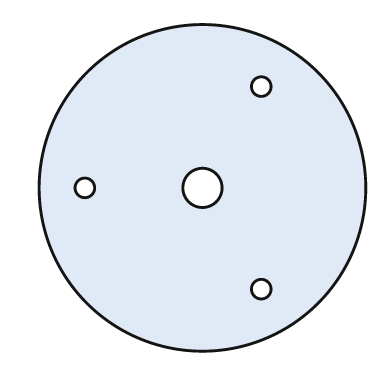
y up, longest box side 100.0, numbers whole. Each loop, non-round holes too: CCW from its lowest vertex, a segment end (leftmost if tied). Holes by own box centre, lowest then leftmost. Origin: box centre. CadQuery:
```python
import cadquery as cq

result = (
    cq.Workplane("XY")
    .moveTo(0.0, 0.0)
    .circle(50.0)
    .moveTo(18.0, -31.0)
    .circle(3.0)
    .moveTo(-36.0, 0.0)
    .circle(3.0)
    .moveTo(0.0, 0.0)
    .circle(6.0)
    .moveTo(18.0, 31.0)
    .circle(3.0)
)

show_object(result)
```